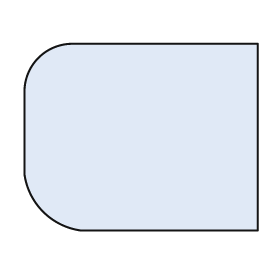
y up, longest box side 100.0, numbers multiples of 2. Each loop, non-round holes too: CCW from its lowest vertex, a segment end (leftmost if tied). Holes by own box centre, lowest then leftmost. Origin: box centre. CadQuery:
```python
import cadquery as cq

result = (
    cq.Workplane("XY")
    .moveTo(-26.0, -40.0)
    .lineTo(50.0, -40.0)
    .lineTo(50.0, 40.0)
    .lineTo(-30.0, 40.0)
    .threePointArc((-44.0, 34.0), (-50.0, 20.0))
    .lineTo(-50.0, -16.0)
    .threePointArc((-42.0, -32.0), (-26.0, -40.0))
    .close()
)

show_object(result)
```